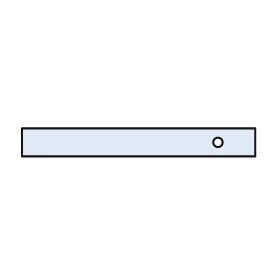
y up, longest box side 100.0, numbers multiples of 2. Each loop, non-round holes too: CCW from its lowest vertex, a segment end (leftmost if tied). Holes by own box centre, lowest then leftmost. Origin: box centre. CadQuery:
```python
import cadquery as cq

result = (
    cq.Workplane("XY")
    .moveTo(-50.0, -6.0)
    .lineTo(50.0, -6.0)
    .lineTo(50.0, 6.0)
    .lineTo(-50.0, 6.0)
    .close()
    .moveTo(34.0, 0.0)
    .circle(2.0)
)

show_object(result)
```